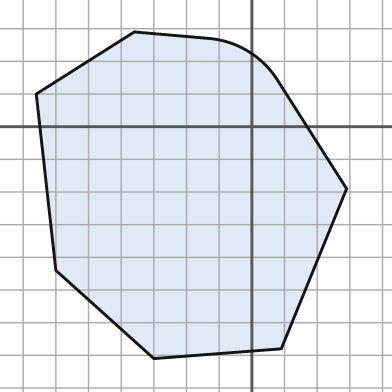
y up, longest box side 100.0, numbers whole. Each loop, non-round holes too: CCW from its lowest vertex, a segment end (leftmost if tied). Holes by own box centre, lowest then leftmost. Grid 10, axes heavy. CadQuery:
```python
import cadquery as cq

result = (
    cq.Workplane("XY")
    .moveTo(-30.0, -71.0)
    .lineTo(9.0, -68.0)
    .lineTo(29.0, -19.0)
    .lineTo(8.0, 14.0)
    .threePointArc((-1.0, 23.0), (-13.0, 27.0))
    .lineTo(-36.0, 29.0)
    .lineTo(-66.0, 10.0)
    .lineTo(-60.0, -44.0)
    .close()
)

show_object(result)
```